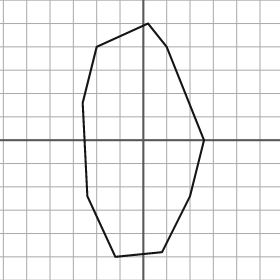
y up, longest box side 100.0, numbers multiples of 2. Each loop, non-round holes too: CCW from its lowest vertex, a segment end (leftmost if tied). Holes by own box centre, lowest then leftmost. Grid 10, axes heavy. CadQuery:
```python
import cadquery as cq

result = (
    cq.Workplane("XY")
    .moveTo(-12.0, -50.0)
    .lineTo(8.0, -48.0)
    .lineTo(20.0, -24.0)
    .lineTo(26.0, 0.0)
    .lineTo(10.0, 40.0)
    .lineTo(2.0, 50.0)
    .lineTo(-20.0, 40.0)
    .lineTo(-26.0, 16.0)
    .lineTo(-24.0, -24.0)
    .close()
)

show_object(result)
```